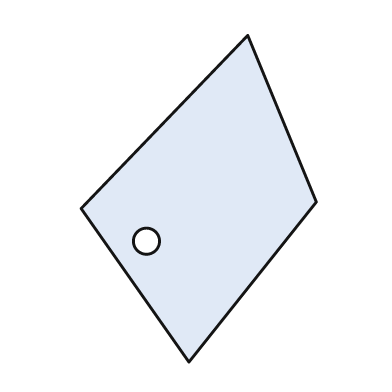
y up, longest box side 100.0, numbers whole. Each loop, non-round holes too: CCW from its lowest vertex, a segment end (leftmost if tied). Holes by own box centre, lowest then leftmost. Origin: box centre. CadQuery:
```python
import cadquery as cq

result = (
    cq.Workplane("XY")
    .moveTo(-3.0, -50.0)
    .lineTo(36.0, -1.0)
    .lineTo(15.0, 50.0)
    .lineTo(-36.0, -3.0)
    .close()
    .moveTo(-16.0, -13.0)
    .circle(4.0)
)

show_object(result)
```